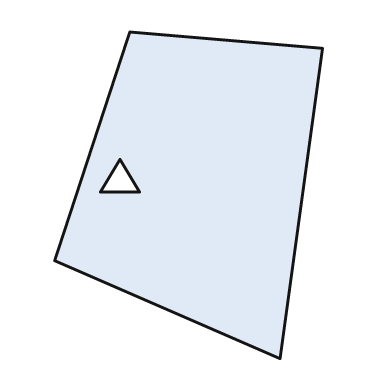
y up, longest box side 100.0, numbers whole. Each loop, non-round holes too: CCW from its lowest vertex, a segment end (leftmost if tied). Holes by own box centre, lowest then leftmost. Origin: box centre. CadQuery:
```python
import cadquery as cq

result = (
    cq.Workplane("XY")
    .moveTo(28.0, -50.0)
    .lineTo(41.0, 45.0)
    .lineTo(-18.0, 50.0)
    .lineTo(-41.0, -20.0)
    .close()
    .moveTo(-27.0, 1.0)
    .lineTo(-15.0, 1.0)
    .lineTo(-21.0, 11.0)
    .close()
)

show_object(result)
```